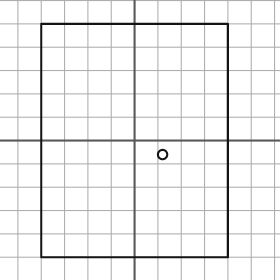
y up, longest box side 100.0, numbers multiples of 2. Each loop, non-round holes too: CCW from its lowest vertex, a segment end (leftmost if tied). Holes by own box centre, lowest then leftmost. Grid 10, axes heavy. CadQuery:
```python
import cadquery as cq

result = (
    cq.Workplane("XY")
    .moveTo(-40.0, -50.0)
    .lineTo(40.0, -50.0)
    .lineTo(40.0, 50.0)
    .lineTo(-40.0, 50.0)
    .close()
    .moveTo(12.0, -6.0)
    .circle(2.0)
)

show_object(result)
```